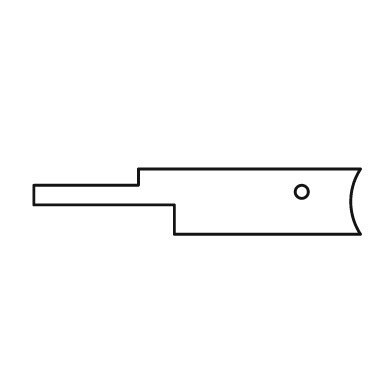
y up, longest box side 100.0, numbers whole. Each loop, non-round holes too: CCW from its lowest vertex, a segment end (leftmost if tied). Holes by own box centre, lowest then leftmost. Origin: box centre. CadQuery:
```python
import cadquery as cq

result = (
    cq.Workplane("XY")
    .moveTo(-7.0, -10.0)
    .lineTo(50.0, -10.0)
    .threePointArc((47.0, 0.0), (50.0, 10.0))
    .lineTo(-18.0, 10.0)
    .lineTo(-18.0, 5.0)
    .lineTo(-50.0, 5.0)
    .lineTo(-50.0, -1.0)
    .lineTo(-7.0, -1.0)
    .close()
    .moveTo(32.0, 3.0)
    .circle(2.0)
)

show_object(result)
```